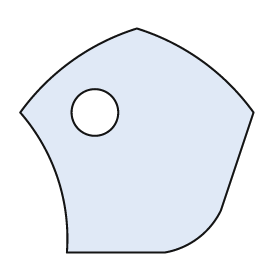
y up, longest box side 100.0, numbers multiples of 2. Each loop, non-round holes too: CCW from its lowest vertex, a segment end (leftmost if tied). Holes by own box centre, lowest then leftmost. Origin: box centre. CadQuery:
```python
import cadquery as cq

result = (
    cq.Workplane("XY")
    .moveTo(-30.0, -48.0)
    .lineTo(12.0, -48.0)
    .threePointArc((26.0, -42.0), (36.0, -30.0))
    .lineTo(50.0, 12.0)
    .threePointArc((28.0, 34.0), (0.0, 48.0))
    .threePointArc((-28.0, 34.0), (-50.0, 12.0))
    .threePointArc((-34.0, -16.0), (-30.0, -48.0))
    .close()
    .moveTo(-18.0, 12.0)
    .circle(10.0)
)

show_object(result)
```